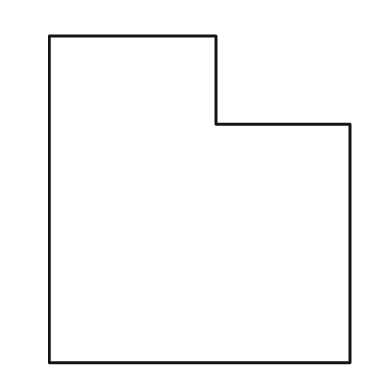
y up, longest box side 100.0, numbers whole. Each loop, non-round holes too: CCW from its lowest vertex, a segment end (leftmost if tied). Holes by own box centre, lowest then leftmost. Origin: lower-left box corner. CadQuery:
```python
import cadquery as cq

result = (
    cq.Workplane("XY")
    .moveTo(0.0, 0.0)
    .lineTo(92.0, 0.0)
    .lineTo(92.0, 73.0)
    .lineTo(51.0, 73.0)
    .lineTo(51.0, 100.0)
    .lineTo(0.0, 100.0)
    .close()
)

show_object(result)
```